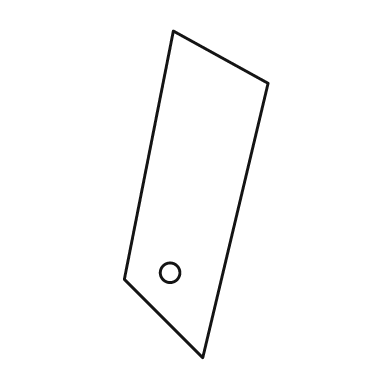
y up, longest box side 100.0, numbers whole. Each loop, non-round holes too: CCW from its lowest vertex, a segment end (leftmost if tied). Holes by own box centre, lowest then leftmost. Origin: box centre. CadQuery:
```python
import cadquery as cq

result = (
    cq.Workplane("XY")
    .moveTo(2.0, -50.0)
    .lineTo(22.0, 34.0)
    .lineTo(-7.0, 50.0)
    .lineTo(-22.0, -26.0)
    .close()
    .moveTo(-8.0, -24.0)
    .circle(3.0)
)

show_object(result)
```